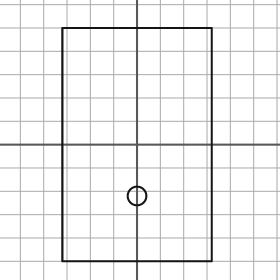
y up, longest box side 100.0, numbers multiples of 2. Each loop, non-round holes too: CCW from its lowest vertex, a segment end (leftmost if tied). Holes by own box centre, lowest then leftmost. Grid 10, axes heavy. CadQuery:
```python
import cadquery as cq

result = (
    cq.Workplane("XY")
    .moveTo(-32.0, -50.0)
    .lineTo(32.0, -50.0)
    .lineTo(32.0, 50.0)
    .lineTo(-32.0, 50.0)
    .close()
    .moveTo(0.0, -22.0)
    .circle(4.0)
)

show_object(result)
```